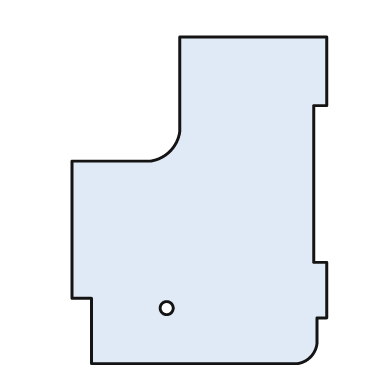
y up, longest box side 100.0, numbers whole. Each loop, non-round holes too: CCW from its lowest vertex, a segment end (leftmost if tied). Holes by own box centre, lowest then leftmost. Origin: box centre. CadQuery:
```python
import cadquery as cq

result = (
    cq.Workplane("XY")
    .moveTo(-33.0, -50.0)
    .lineTo(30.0, -50.0)
    .threePointArc((34.0, -48.0), (36.0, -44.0))
    .lineTo(36.0, -36.0)
    .lineTo(39.0, -36.0)
    .lineTo(39.0, -19.0)
    .lineTo(35.0, -19.0)
    .lineTo(35.0, 29.0)
    .lineTo(39.0, 29.0)
    .lineTo(39.0, 50.0)
    .lineTo(-6.0, 50.0)
    .lineTo(-6.0, 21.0)
    .threePointArc((-9.0, 15.0), (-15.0, 12.0))
    .lineTo(-39.0, 12.0)
    .lineTo(-39.0, -30.0)
    .lineTo(-33.0, -30.0)
    .close()
    .moveTo(-10.0, -33.0)
    .circle(2.0)
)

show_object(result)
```